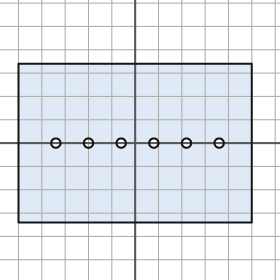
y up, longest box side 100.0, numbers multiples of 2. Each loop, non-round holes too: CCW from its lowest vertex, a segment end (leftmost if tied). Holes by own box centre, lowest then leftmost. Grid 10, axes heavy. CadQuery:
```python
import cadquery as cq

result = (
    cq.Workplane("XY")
    .moveTo(-50.0, -34.0)
    .lineTo(50.0, -34.0)
    .lineTo(50.0, 34.0)
    .lineTo(-50.0, 34.0)
    .close()
    .moveTo(-34.0, 0.0)
    .circle(2.0)
    .moveTo(-20.0, 0.0)
    .circle(2.0)
    .moveTo(-6.0, 0.0)
    .circle(2.0)
    .moveTo(8.0, 0.0)
    .circle(2.0)
    .moveTo(22.0, 0.0)
    .circle(2.0)
    .moveTo(36.0, 0.0)
    .circle(2.0)
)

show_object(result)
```